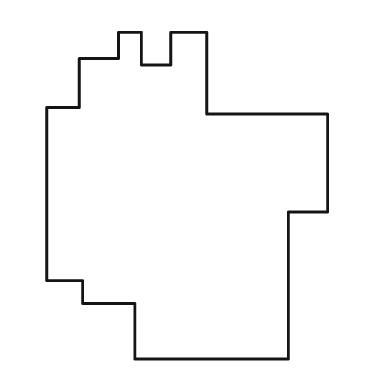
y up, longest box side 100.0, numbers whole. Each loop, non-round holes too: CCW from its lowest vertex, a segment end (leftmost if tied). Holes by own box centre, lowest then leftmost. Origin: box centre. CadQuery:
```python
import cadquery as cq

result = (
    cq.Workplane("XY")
    .moveTo(-16.0, -50.0)
    .lineTo(31.0, -50.0)
    .lineTo(31.0, -5.0)
    .lineTo(43.0, -5.0)
    .lineTo(43.0, 25.0)
    .lineTo(6.0, 25.0)
    .lineTo(6.0, 50.0)
    .lineTo(-5.0, 50.0)
    .lineTo(-5.0, 40.0)
    .lineTo(-14.0, 40.0)
    .lineTo(-14.0, 50.0)
    .lineTo(-21.0, 50.0)
    .lineTo(-21.0, 42.0)
    .lineTo(-33.0, 42.0)
    .lineTo(-33.0, 27.0)
    .lineTo(-43.0, 27.0)
    .lineTo(-43.0, -26.0)
    .lineTo(-32.0, -26.0)
    .lineTo(-32.0, -33.0)
    .lineTo(-16.0, -33.0)
    .close()
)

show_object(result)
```